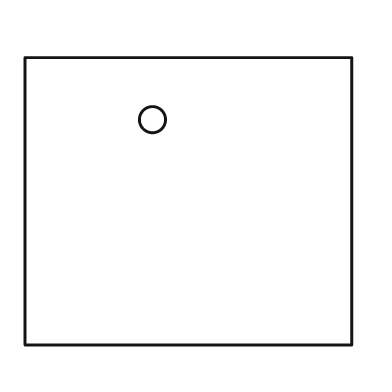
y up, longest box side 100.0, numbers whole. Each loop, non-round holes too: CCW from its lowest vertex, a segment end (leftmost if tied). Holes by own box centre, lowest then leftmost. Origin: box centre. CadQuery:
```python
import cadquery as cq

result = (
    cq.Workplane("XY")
    .moveTo(-50.0, -44.0)
    .lineTo(50.0, -44.0)
    .lineTo(50.0, 44.0)
    .lineTo(-50.0, 44.0)
    .close()
    .moveTo(-11.0, 25.0)
    .circle(4.0)
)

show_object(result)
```